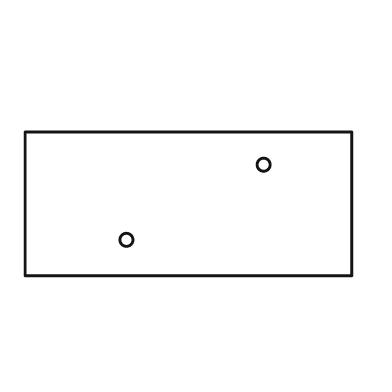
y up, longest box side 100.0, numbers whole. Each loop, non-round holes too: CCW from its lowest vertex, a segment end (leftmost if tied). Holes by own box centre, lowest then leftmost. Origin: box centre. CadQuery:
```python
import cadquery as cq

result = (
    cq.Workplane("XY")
    .moveTo(-50.0, -22.0)
    .lineTo(50.0, -22.0)
    .lineTo(50.0, 22.0)
    .lineTo(-50.0, 22.0)
    .close()
    .moveTo(-19.0, -11.0)
    .circle(2.0)
    .moveTo(23.0, 12.0)
    .circle(2.0)
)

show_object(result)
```